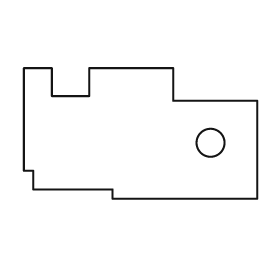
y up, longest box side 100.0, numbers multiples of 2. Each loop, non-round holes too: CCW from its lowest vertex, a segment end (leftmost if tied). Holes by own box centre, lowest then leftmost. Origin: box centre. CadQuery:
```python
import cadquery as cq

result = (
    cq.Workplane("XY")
    .moveTo(-12.0, -28.0)
    .lineTo(50.0, -28.0)
    .lineTo(50.0, 14.0)
    .lineTo(14.0, 14.0)
    .lineTo(14.0, 28.0)
    .lineTo(-22.0, 28.0)
    .lineTo(-22.0, 16.0)
    .lineTo(-38.0, 16.0)
    .lineTo(-38.0, 28.0)
    .lineTo(-50.0, 28.0)
    .lineTo(-50.0, -16.0)
    .lineTo(-46.0, -16.0)
    .lineTo(-46.0, -24.0)
    .lineTo(-12.0, -24.0)
    .close()
    .moveTo(30.0, -4.0)
    .circle(6.0)
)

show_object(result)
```